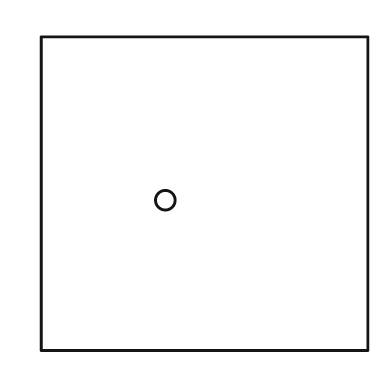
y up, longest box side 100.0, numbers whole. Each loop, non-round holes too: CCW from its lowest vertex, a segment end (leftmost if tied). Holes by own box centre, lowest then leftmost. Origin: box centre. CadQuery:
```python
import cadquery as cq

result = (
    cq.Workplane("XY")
    .moveTo(-50.0, -48.0)
    .lineTo(50.0, -48.0)
    .lineTo(50.0, 48.0)
    .lineTo(-50.0, 48.0)
    .close()
    .moveTo(-12.0, -2.0)
    .circle(3.0)
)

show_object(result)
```